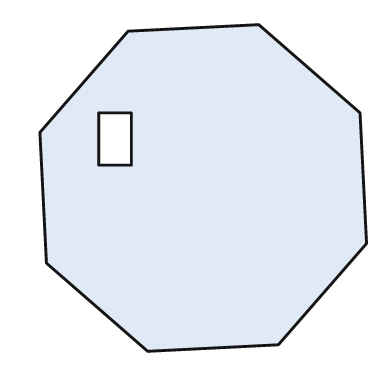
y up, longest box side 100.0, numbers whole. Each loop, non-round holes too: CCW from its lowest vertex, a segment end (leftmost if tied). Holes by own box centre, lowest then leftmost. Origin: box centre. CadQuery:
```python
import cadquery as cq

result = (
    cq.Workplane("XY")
    .moveTo(-17.0, -50.0)
    .lineTo(23.0, -48.0)
    .lineTo(50.0, -17.0)
    .lineTo(48.0, 23.0)
    .lineTo(17.0, 50.0)
    .lineTo(-23.0, 48.0)
    .lineTo(-50.0, 17.0)
    .lineTo(-48.0, -23.0)
    .close()
    .moveTo(-32.0, 7.0)
    .lineTo(-22.0, 7.0)
    .lineTo(-22.0, 23.0)
    .lineTo(-32.0, 23.0)
    .close()
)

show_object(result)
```